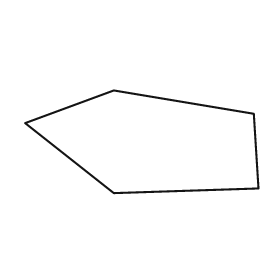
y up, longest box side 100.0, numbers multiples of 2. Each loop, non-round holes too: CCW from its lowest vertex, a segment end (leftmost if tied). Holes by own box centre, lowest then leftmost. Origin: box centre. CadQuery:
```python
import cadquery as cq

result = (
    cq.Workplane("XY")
    .moveTo(-12.0, -22.0)
    .lineTo(50.0, -20.0)
    .lineTo(48.0, 12.0)
    .lineTo(-12.0, 22.0)
    .lineTo(-50.0, 8.0)
    .close()
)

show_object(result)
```